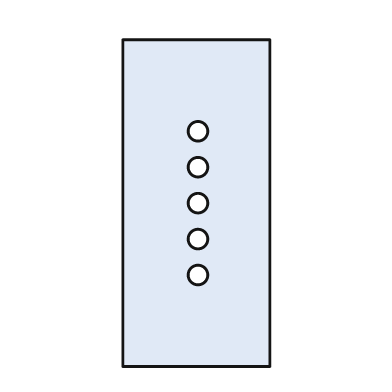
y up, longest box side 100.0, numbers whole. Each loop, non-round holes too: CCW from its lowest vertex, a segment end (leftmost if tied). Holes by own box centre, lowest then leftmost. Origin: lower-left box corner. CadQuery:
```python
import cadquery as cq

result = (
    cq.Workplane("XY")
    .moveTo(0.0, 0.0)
    .lineTo(45.0, 0.0)
    .lineTo(45.0, 100.0)
    .lineTo(0.0, 100.0)
    .close()
    .moveTo(23.0, 28.0)
    .circle(3.0)
    .moveTo(23.0, 39.0)
    .circle(3.0)
    .moveTo(23.0, 50.0)
    .circle(3.0)
    .moveTo(23.0, 61.0)
    .circle(3.0)
    .moveTo(23.0, 72.0)
    .circle(3.0)
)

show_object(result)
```